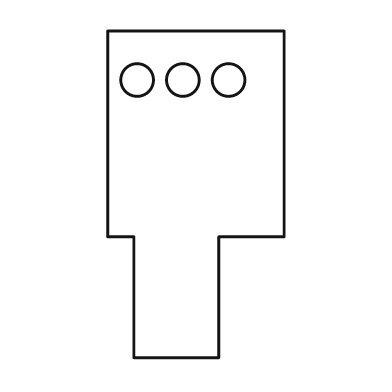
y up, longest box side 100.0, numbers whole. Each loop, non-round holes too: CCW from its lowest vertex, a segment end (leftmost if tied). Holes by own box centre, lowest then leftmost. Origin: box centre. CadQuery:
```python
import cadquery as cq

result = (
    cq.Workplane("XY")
    .moveTo(-19.0, -50.0)
    .lineTo(7.0, -50.0)
    .lineTo(7.0, -13.0)
    .lineTo(27.0, -13.0)
    .lineTo(27.0, 50.0)
    .lineTo(-27.0, 50.0)
    .lineTo(-27.0, -13.0)
    .lineTo(-19.0, -13.0)
    .close()
    .moveTo(-18.0, 35.0)
    .circle(5.0)
    .moveTo(-4.0, 35.0)
    .circle(5.0)
    .moveTo(10.0, 35.0)
    .circle(5.0)
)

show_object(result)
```